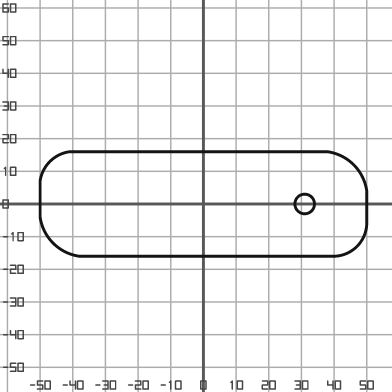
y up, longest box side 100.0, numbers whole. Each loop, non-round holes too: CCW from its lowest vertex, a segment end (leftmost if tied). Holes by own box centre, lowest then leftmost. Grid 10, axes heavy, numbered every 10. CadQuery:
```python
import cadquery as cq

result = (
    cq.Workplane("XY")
    .moveTo(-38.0, -16.0)
    .lineTo(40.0, -16.0)
    .threePointArc((47.0, -13.0), (50.0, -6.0))
    .lineTo(50.0, 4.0)
    .threePointArc((46.0, 12.0), (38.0, 16.0))
    .lineTo(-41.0, 16.0)
    .threePointArc((-47.0, 13.0), (-50.0, 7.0))
    .lineTo(-50.0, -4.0)
    .threePointArc((-46.0, -12.0), (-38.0, -16.0))
    .close()
    .moveTo(31.0, 0.0)
    .circle(3.0)
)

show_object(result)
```